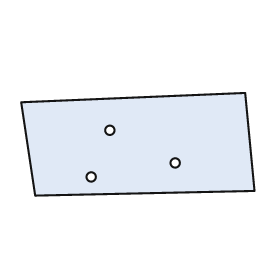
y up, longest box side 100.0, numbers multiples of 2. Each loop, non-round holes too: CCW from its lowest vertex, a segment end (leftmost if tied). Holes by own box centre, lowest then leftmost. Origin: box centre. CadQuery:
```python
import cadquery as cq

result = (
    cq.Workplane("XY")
    .moveTo(-44.0, -22.0)
    .lineTo(50.0, -20.0)
    .lineTo(46.0, 22.0)
    .lineTo(-50.0, 18.0)
    .close()
    .moveTo(-20.0, -14.0)
    .circle(2.0)
    .moveTo(16.0, -8.0)
    .circle(2.0)
    .moveTo(-12.0, 6.0)
    .circle(2.0)
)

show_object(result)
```